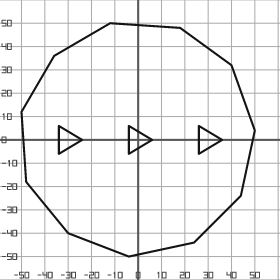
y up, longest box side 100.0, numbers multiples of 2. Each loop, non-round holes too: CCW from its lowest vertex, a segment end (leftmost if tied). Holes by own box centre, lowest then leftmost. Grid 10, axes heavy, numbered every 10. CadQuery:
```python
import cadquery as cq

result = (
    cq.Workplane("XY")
    .moveTo(-4.0, -50.0)
    .lineTo(24.0, -44.0)
    .lineTo(44.0, -24.0)
    .lineTo(50.0, 4.0)
    .lineTo(40.0, 32.0)
    .lineTo(18.0, 48.0)
    .lineTo(-12.0, 50.0)
    .lineTo(-36.0, 36.0)
    .lineTo(-50.0, 12.0)
    .lineTo(-48.0, -18.0)
    .lineTo(-30.0, -40.0)
    .close()
    .moveTo(-34.0, -6.0)
    .lineTo(-24.0, 0.0)
    .lineTo(-34.0, 6.0)
    .close()
    .moveTo(-4.0, -6.0)
    .lineTo(6.0, 0.0)
    .lineTo(-4.0, 6.0)
    .close()
    .moveTo(26.0, -6.0)
    .lineTo(36.0, 0.0)
    .lineTo(26.0, 6.0)
    .close()
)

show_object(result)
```